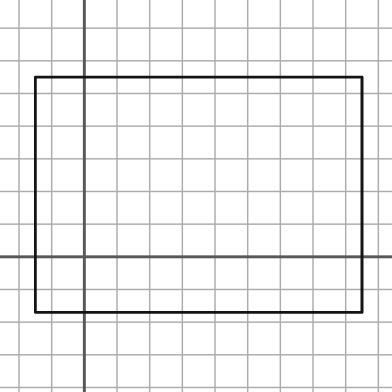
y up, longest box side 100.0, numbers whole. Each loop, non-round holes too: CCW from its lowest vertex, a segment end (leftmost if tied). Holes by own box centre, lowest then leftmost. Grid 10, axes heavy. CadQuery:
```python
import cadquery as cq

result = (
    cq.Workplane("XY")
    .moveTo(-15.0, -17.0)
    .lineTo(85.0, -17.0)
    .lineTo(85.0, 55.0)
    .lineTo(-15.0, 55.0)
    .close()
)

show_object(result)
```